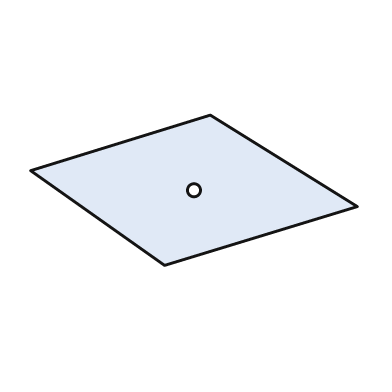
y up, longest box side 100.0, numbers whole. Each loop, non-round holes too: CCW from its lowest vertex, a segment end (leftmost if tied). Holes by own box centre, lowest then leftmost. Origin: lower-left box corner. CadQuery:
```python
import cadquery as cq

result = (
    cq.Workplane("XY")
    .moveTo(41.0, 0.0)
    .lineTo(100.0, 18.0)
    .lineTo(55.0, 46.0)
    .lineTo(0.0, 29.0)
    .close()
    .moveTo(50.0, 23.0)
    .circle(2.0)
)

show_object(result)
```